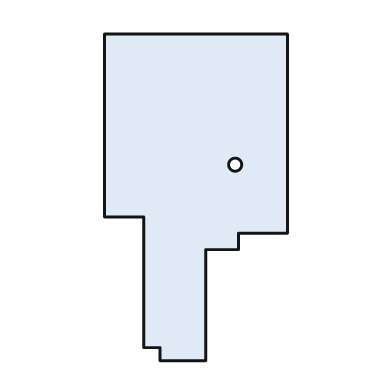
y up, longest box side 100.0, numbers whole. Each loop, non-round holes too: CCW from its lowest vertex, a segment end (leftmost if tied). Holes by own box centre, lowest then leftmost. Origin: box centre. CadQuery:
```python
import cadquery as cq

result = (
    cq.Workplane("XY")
    .moveTo(-11.0, -50.0)
    .lineTo(3.0, -50.0)
    .lineTo(3.0, -16.0)
    .lineTo(13.0, -16.0)
    .lineTo(13.0, -11.0)
    .lineTo(28.0, -11.0)
    .lineTo(28.0, 50.0)
    .lineTo(-28.0, 50.0)
    .lineTo(-28.0, -6.0)
    .lineTo(-16.0, -6.0)
    .lineTo(-16.0, -46.0)
    .lineTo(-11.0, -46.0)
    .close()
    .moveTo(12.0, 10.0)
    .circle(2.0)
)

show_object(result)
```